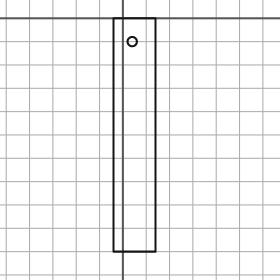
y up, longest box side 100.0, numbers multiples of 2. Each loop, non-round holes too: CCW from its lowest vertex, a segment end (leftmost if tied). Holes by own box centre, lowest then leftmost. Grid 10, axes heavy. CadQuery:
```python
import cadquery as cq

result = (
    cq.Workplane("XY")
    .moveTo(-4.0, -100.0)
    .lineTo(14.0, -100.0)
    .lineTo(14.0, 0.0)
    .lineTo(-4.0, 0.0)
    .close()
    .moveTo(4.0, -10.0)
    .circle(2.0)
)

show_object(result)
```